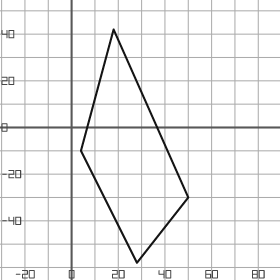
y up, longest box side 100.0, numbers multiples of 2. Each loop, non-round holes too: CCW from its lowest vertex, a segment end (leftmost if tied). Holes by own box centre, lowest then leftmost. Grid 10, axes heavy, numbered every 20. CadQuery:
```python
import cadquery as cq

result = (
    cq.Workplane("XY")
    .moveTo(28.0, -58.0)
    .lineTo(50.0, -30.0)
    .lineTo(18.0, 42.0)
    .lineTo(4.0, -10.0)
    .close()
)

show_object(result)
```